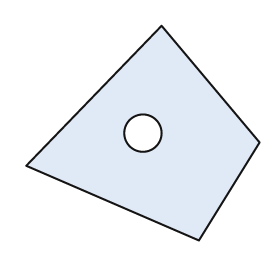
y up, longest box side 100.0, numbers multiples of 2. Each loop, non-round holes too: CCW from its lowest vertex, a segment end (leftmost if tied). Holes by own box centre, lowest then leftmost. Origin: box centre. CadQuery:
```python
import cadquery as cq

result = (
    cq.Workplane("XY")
    .moveTo(24.0, -46.0)
    .lineTo(50.0, -4.0)
    .lineTo(8.0, 46.0)
    .lineTo(-50.0, -14.0)
    .close()
    .moveTo(0.0, 0.0)
    .circle(8.0)
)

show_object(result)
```